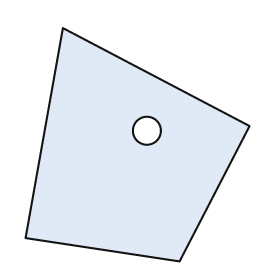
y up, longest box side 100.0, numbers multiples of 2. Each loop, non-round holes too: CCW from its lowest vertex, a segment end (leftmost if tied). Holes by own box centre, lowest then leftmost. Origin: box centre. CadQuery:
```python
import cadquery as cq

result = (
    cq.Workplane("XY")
    .moveTo(18.0, -50.0)
    .lineTo(48.0, 8.0)
    .lineTo(-32.0, 50.0)
    .lineTo(-48.0, -40.0)
    .close()
    .moveTo(4.0, 6.0)
    .circle(6.0)
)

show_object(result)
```